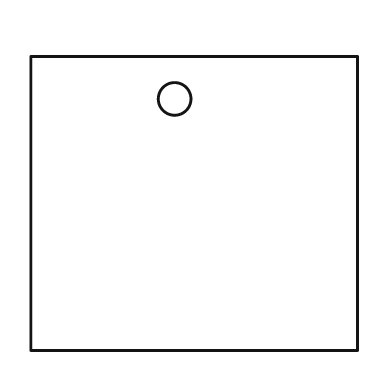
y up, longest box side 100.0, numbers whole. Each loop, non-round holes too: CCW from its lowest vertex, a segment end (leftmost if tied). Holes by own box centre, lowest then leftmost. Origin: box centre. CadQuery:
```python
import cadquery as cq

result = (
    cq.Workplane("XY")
    .moveTo(-50.0, -45.0)
    .lineTo(50.0, -45.0)
    .lineTo(50.0, 45.0)
    .lineTo(-50.0, 45.0)
    .close()
    .moveTo(-6.0, 32.0)
    .circle(5.0)
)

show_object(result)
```